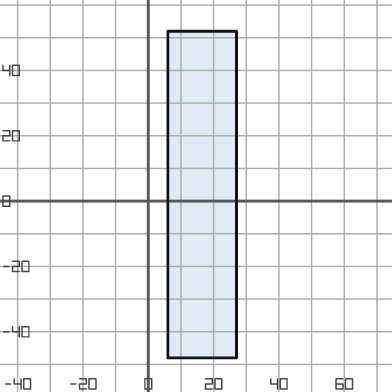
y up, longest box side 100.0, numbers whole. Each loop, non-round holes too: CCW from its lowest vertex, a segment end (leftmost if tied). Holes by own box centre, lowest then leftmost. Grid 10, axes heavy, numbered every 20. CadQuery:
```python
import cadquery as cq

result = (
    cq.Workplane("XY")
    .moveTo(6.0, -48.0)
    .lineTo(27.0, -48.0)
    .lineTo(27.0, 52.0)
    .lineTo(6.0, 52.0)
    .close()
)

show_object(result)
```